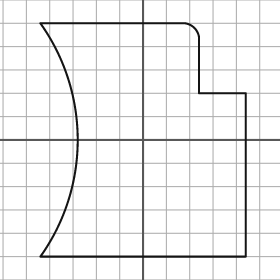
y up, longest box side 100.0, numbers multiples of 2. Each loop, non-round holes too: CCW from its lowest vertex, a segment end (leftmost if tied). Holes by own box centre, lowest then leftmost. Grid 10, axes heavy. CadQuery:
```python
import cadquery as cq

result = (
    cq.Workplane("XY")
    .moveTo(-44.0, -50.0)
    .lineTo(44.0, -50.0)
    .lineTo(44.0, 20.0)
    .lineTo(24.0, 20.0)
    .lineTo(24.0, 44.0)
    .threePointArc((22.0, 48.0), (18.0, 50.0))
    .lineTo(-44.0, 50.0)
    .threePointArc((-28.0, 0.0), (-44.0, -50.0))
    .close()
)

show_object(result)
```